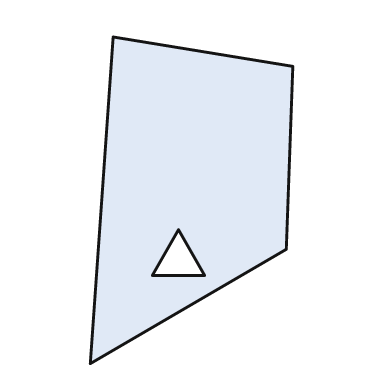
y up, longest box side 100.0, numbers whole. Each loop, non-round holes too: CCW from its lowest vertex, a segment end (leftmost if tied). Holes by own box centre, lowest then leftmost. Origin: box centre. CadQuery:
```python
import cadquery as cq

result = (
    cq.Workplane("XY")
    .moveTo(-31.0, -50.0)
    .lineTo(29.0, -15.0)
    .lineTo(31.0, 41.0)
    .lineTo(-24.0, 50.0)
    .close()
    .moveTo(-12.0, -23.0)
    .lineTo(4.0, -23.0)
    .lineTo(-4.0, -9.0)
    .close()
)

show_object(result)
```